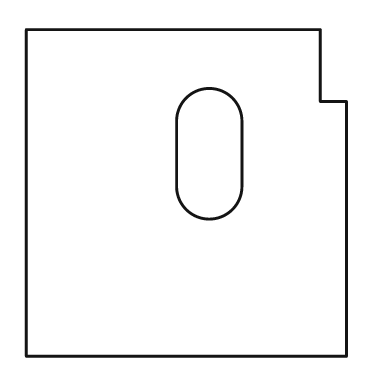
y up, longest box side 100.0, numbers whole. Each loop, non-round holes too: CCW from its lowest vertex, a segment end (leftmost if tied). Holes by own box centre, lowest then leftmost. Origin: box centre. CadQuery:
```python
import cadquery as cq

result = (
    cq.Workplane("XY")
    .moveTo(-49.0, -50.0)
    .lineTo(49.0, -50.0)
    .lineTo(49.0, 28.0)
    .lineTo(41.0, 28.0)
    .lineTo(41.0, 50.0)
    .lineTo(-49.0, 50.0)
    .close()
    .moveTo(-3.0, 2.0)
    .threePointArc((7.0, -8.0), (17.0, 2.0))
    .lineTo(17.0, 22.0)
    .threePointArc((7.0, 32.0), (-3.0, 22.0))
    .close()
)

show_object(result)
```